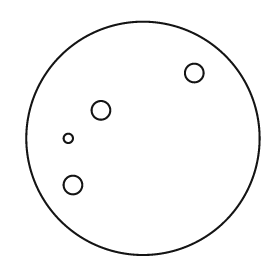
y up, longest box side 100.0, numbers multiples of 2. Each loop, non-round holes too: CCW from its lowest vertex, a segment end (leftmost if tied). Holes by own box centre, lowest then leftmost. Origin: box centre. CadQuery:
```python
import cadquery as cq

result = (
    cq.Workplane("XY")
    .moveTo(0.0, 0.0)
    .circle(50.0)
    .moveTo(-30.0, -20.0)
    .circle(4.0)
    .moveTo(-32.0, 0.0)
    .circle(2.0)
    .moveTo(-18.0, 12.0)
    .circle(4.0)
    .moveTo(22.0, 28.0)
    .circle(4.0)
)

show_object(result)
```